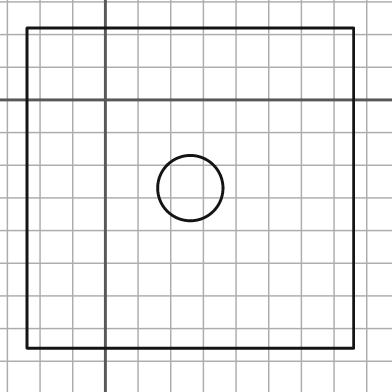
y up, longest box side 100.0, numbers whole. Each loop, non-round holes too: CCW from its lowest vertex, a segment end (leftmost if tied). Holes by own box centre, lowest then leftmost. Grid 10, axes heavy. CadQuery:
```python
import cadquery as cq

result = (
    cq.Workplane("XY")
    .moveTo(-24.0, -76.0)
    .lineTo(76.0, -76.0)
    .lineTo(76.0, 22.0)
    .lineTo(-24.0, 22.0)
    .close()
    .moveTo(26.0, -27.0)
    .circle(10.0)
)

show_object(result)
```